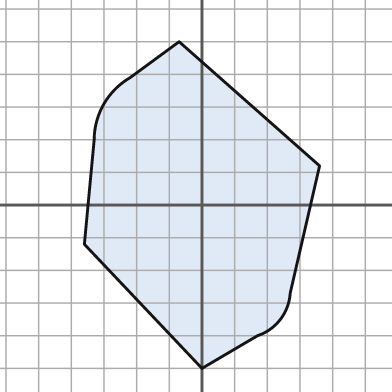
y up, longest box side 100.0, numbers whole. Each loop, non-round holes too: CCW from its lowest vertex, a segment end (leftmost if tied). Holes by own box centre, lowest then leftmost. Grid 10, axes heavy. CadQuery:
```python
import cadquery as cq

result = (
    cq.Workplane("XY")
    .moveTo(0.0, -50.0)
    .lineTo(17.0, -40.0)
    .threePointArc((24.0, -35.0), (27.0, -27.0))
    .lineTo(36.0, 12.0)
    .lineTo(-7.0, 50.0)
    .lineTo(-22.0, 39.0)
    .threePointArc((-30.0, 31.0), (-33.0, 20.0))
    .lineTo(-36.0, -12.0)
    .close()
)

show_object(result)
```